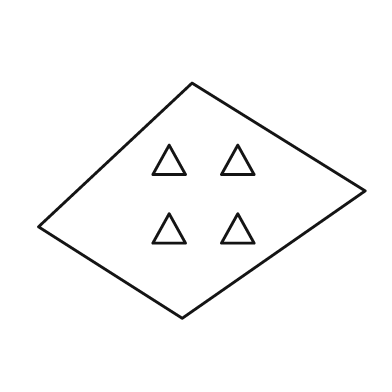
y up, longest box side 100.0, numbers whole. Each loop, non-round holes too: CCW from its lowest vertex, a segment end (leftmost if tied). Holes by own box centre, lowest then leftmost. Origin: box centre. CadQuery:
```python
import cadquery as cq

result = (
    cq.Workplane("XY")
    .moveTo(-6.0, -36.0)
    .lineTo(50.0, 3.0)
    .lineTo(-3.0, 36.0)
    .lineTo(-50.0, -8.0)
    .close()
    .moveTo(-15.0, -13.0)
    .lineTo(-5.0, -13.0)
    .lineTo(-10.0, -4.0)
    .close()
    .moveTo(6.0, -13.0)
    .lineTo(16.0, -13.0)
    .lineTo(11.0, -4.0)
    .close()
    .moveTo(-15.0, 8.0)
    .lineTo(-5.0, 8.0)
    .lineTo(-10.0, 17.0)
    .close()
    .moveTo(6.0, 8.0)
    .lineTo(16.0, 8.0)
    .lineTo(11.0, 17.0)
    .close()
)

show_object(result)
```